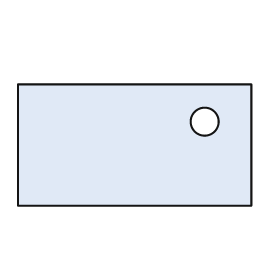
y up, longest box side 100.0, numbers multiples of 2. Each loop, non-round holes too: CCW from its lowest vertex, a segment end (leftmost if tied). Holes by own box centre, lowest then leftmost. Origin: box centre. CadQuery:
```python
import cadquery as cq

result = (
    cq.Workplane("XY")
    .moveTo(-50.0, -26.0)
    .lineTo(50.0, -26.0)
    .lineTo(50.0, 26.0)
    .lineTo(-50.0, 26.0)
    .close()
    .moveTo(30.0, 10.0)
    .circle(6.0)
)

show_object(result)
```